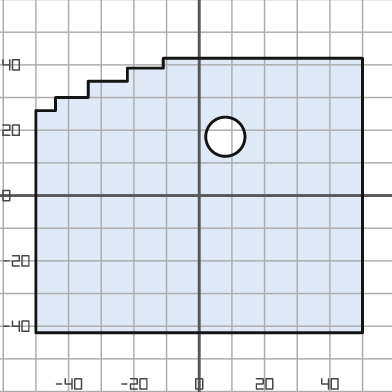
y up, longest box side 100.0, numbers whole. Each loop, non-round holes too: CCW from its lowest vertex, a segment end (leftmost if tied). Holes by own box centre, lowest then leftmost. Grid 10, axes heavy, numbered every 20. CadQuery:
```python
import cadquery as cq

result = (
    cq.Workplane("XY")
    .moveTo(-50.0, -42.0)
    .lineTo(50.0, -42.0)
    .lineTo(50.0, 42.0)
    .lineTo(-11.0, 42.0)
    .lineTo(-11.0, 39.0)
    .lineTo(-22.0, 39.0)
    .lineTo(-22.0, 35.0)
    .lineTo(-34.0, 35.0)
    .lineTo(-34.0, 30.0)
    .lineTo(-44.0, 30.0)
    .lineTo(-44.0, 26.0)
    .lineTo(-50.0, 26.0)
    .close()
    .moveTo(8.0, 18.0)
    .circle(6.0)
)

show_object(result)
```